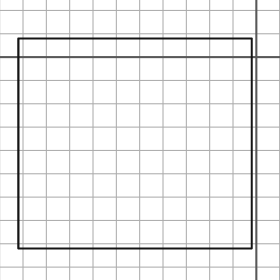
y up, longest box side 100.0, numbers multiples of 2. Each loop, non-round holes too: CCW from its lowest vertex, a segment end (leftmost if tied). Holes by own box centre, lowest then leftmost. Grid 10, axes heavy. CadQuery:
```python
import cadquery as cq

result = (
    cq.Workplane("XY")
    .moveTo(-102.0, -82.0)
    .lineTo(-2.0, -82.0)
    .lineTo(-2.0, 8.0)
    .lineTo(-102.0, 8.0)
    .close()
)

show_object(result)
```